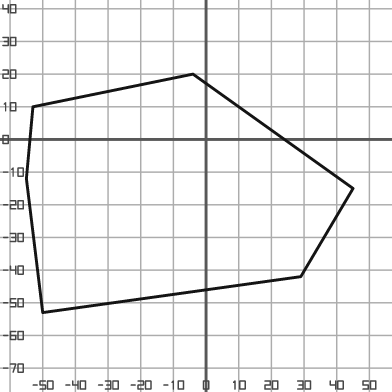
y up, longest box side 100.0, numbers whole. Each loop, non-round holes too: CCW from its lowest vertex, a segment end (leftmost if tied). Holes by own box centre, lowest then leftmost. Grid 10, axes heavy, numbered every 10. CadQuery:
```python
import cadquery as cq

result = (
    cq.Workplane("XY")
    .moveTo(-50.0, -53.0)
    .lineTo(29.0, -42.0)
    .lineTo(45.0, -15.0)
    .lineTo(-4.0, 20.0)
    .lineTo(-53.0, 10.0)
    .lineTo(-55.0, -12.0)
    .close()
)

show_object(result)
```